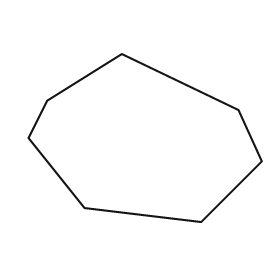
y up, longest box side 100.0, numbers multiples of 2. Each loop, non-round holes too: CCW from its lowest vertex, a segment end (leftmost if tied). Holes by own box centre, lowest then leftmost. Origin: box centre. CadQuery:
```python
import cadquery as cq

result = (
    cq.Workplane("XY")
    .moveTo(24.0, -36.0)
    .lineTo(50.0, -10.0)
    .lineTo(40.0, 12.0)
    .lineTo(-10.0, 36.0)
    .lineTo(-42.0, 16.0)
    .lineTo(-50.0, 0.0)
    .lineTo(-26.0, -30.0)
    .close()
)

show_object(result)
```